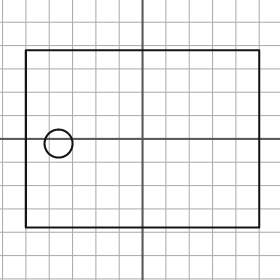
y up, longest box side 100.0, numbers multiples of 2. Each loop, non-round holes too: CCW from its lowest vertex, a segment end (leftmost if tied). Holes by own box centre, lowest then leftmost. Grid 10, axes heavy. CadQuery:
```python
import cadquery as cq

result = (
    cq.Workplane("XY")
    .moveTo(-50.0, -38.0)
    .lineTo(50.0, -38.0)
    .lineTo(50.0, 38.0)
    .lineTo(-50.0, 38.0)
    .close()
    .moveTo(-36.0, -2.0)
    .circle(6.0)
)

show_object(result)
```